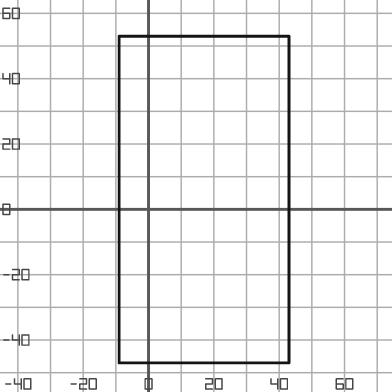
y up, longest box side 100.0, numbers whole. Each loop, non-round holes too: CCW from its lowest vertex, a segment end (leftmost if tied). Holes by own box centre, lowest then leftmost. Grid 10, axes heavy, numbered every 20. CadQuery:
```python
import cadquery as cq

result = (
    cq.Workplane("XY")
    .moveTo(-9.0, -47.0)
    .lineTo(43.0, -47.0)
    .lineTo(43.0, 53.0)
    .lineTo(-9.0, 53.0)
    .close()
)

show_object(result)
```